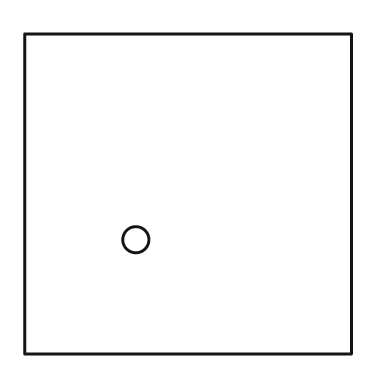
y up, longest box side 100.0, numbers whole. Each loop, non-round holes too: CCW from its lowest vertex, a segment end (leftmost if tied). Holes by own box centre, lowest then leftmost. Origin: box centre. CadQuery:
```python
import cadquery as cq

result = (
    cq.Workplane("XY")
    .moveTo(-50.0, -49.0)
    .lineTo(50.0, -49.0)
    .lineTo(50.0, 49.0)
    .lineTo(-50.0, 49.0)
    .close()
    .moveTo(-16.0, -14.0)
    .circle(4.0)
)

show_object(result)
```